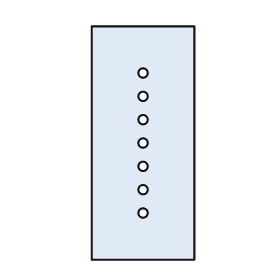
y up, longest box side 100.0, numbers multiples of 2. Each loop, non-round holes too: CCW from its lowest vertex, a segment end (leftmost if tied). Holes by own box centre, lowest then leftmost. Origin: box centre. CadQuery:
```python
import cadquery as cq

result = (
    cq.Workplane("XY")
    .moveTo(-22.0, -50.0)
    .lineTo(22.0, -50.0)
    .lineTo(22.0, 50.0)
    .lineTo(-22.0, 50.0)
    .close()
    .moveTo(0.0, -30.0)
    .circle(2.0)
    .moveTo(0.0, -20.0)
    .circle(2.0)
    .moveTo(0.0, -10.0)
    .circle(2.0)
    .moveTo(0.0, 0.0)
    .circle(2.0)
    .moveTo(0.0, 10.0)
    .circle(2.0)
    .moveTo(0.0, 20.0)
    .circle(2.0)
    .moveTo(0.0, 30.0)
    .circle(2.0)
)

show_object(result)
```